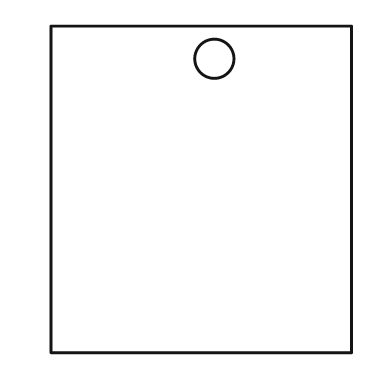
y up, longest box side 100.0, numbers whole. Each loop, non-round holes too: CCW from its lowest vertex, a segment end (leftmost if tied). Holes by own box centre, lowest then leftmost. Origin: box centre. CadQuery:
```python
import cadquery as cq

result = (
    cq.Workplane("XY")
    .moveTo(-46.0, -50.0)
    .lineTo(46.0, -50.0)
    .lineTo(46.0, 50.0)
    .lineTo(-46.0, 50.0)
    .close()
    .moveTo(4.0, 40.0)
    .circle(6.0)
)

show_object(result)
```